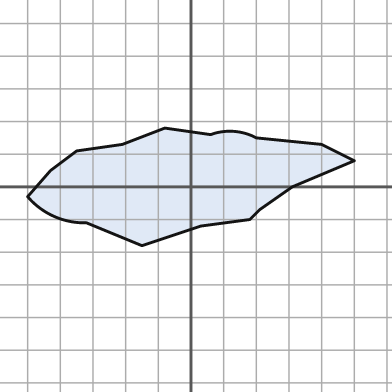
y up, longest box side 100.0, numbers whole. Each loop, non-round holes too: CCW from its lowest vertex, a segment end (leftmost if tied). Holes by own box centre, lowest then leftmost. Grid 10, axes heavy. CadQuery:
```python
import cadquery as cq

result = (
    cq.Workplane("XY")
    .moveTo(-15.0, -18.0)
    .lineTo(3.0, -12.0)
    .lineTo(18.0, -10.0)
    .lineTo(21.0, -7.0)
    .lineTo(31.0, 0.0)
    .lineTo(50.0, 8.0)
    .lineTo(40.0, 13.0)
    .lineTo(20.0, 15.0)
    .threePointArc((13.0, 17.0), (6.0, 16.0))
    .lineTo(-8.0, 18.0)
    .lineTo(-21.0, 13.0)
    .lineTo(-35.0, 11.0)
    .lineTo(-43.0, 5.0)
    .lineTo(-50.0, -3.0)
    .threePointArc((-42.0, -9.0), (-32.0, -11.0))
    .close()
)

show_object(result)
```